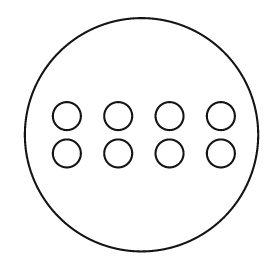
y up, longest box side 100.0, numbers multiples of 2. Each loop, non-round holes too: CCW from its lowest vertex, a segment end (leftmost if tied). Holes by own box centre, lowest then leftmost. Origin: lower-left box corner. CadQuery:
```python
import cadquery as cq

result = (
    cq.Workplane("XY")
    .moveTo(50.0, 50.0)
    .circle(50.0)
    .moveTo(18.0, 42.0)
    .circle(6.0)
    .moveTo(40.0, 42.0)
    .circle(6.0)
    .moveTo(62.0, 42.0)
    .circle(6.0)
    .moveTo(84.0, 42.0)
    .circle(6.0)
    .moveTo(18.0, 58.0)
    .circle(6.0)
    .moveTo(40.0, 58.0)
    .circle(6.0)
    .moveTo(62.0, 58.0)
    .circle(6.0)
    .moveTo(84.0, 58.0)
    .circle(6.0)
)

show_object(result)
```